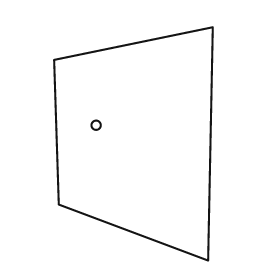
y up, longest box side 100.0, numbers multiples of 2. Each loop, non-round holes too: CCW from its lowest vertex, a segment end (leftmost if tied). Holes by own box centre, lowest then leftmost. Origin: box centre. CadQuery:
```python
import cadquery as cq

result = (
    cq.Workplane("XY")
    .moveTo(32.0, -50.0)
    .lineTo(34.0, 50.0)
    .lineTo(-34.0, 36.0)
    .lineTo(-32.0, -26.0)
    .close()
    .moveTo(-16.0, 8.0)
    .circle(2.0)
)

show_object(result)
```